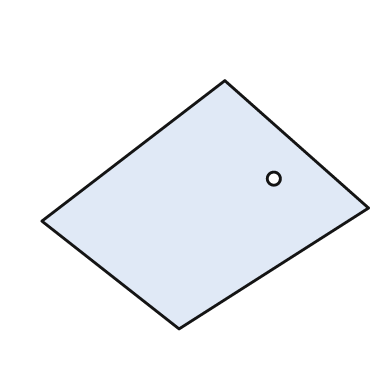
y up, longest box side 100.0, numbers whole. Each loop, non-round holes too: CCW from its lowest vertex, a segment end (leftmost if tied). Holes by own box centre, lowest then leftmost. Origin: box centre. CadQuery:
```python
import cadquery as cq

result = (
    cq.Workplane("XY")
    .moveTo(-8.0, -38.0)
    .lineTo(50.0, -1.0)
    .lineTo(6.0, 38.0)
    .lineTo(-50.0, -5.0)
    .close()
    .moveTo(21.0, 8.0)
    .circle(2.0)
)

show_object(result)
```